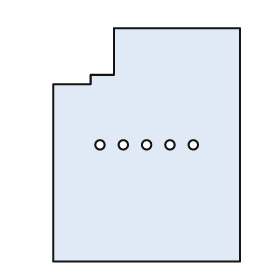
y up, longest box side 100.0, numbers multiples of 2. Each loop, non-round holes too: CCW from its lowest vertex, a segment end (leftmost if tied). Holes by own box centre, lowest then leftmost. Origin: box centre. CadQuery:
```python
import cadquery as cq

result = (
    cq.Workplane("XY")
    .moveTo(-40.0, -50.0)
    .lineTo(40.0, -50.0)
    .lineTo(40.0, 50.0)
    .lineTo(-14.0, 50.0)
    .lineTo(-14.0, 30.0)
    .lineTo(-24.0, 30.0)
    .lineTo(-24.0, 26.0)
    .lineTo(-40.0, 26.0)
    .close()
    .moveTo(-20.0, 0.0)
    .circle(2.0)
    .moveTo(-10.0, 0.0)
    .circle(2.0)
    .moveTo(0.0, 0.0)
    .circle(2.0)
    .moveTo(10.0, 0.0)
    .circle(2.0)
    .moveTo(20.0, 0.0)
    .circle(2.0)
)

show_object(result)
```